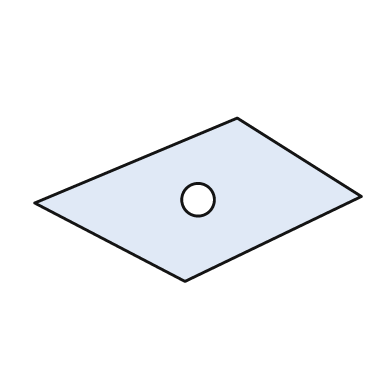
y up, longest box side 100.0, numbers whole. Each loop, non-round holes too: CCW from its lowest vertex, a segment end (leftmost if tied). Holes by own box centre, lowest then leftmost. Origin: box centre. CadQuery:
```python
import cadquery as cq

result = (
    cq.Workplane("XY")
    .moveTo(-4.0, -25.0)
    .lineTo(50.0, 1.0)
    .lineTo(12.0, 25.0)
    .lineTo(-50.0, -1.0)
    .close()
    .moveTo(0.0, 0.0)
    .circle(5.0)
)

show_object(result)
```